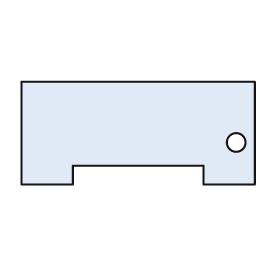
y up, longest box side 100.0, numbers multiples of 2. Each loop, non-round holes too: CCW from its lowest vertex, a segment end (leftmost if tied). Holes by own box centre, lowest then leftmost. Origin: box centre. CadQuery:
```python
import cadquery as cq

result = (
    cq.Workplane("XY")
    .moveTo(-50.0, -22.0)
    .lineTo(-28.0, -22.0)
    .lineTo(-28.0, -14.0)
    .lineTo(28.0, -14.0)
    .lineTo(28.0, -22.0)
    .lineTo(50.0, -22.0)
    .lineTo(50.0, 22.0)
    .lineTo(-50.0, 22.0)
    .close()
    .moveTo(42.0, -4.0)
    .circle(4.0)
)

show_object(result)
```